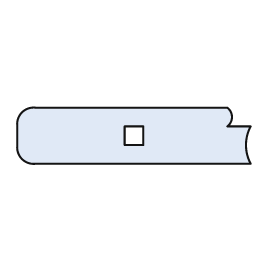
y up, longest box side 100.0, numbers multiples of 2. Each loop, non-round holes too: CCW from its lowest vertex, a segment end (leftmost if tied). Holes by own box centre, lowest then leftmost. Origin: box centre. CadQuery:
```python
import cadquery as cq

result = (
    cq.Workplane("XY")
    .moveTo(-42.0, -12.0)
    .lineTo(50.0, -12.0)
    .threePointArc((48.0, -4.0), (50.0, 4.0))
    .lineTo(40.0, 4.0)
    .threePointArc((42.0, 8.0), (40.0, 12.0))
    .lineTo(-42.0, 12.0)
    .threePointArc((-48.0, 10.0), (-50.0, 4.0))
    .lineTo(-50.0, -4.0)
    .threePointArc((-48.0, -10.0), (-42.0, -12.0))
    .close()
    .moveTo(-4.0, -4.0)
    .lineTo(4.0, -4.0)
    .lineTo(4.0, 4.0)
    .lineTo(-4.0, 4.0)
    .close()
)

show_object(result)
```